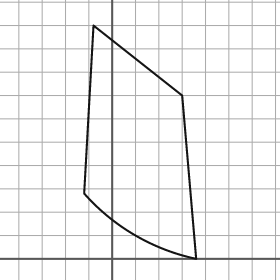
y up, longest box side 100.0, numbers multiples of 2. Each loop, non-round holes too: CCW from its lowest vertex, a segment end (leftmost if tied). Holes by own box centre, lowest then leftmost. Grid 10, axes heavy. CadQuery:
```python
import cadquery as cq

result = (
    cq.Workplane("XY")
    .moveTo(36.0, 0.0)
    .lineTo(30.0, 70.0)
    .lineTo(-8.0, 100.0)
    .lineTo(-12.0, 28.0)
    .threePointArc((10.0, 10.0), (36.0, 0.0))
    .close()
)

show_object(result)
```